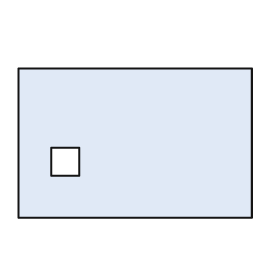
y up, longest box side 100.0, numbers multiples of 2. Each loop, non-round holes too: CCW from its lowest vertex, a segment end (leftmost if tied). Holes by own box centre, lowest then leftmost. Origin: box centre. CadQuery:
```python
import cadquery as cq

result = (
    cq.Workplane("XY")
    .moveTo(-50.0, -32.0)
    .lineTo(50.0, -32.0)
    .lineTo(50.0, 32.0)
    .lineTo(-50.0, 32.0)
    .close()
    .moveTo(-36.0, -14.0)
    .lineTo(-24.0, -14.0)
    .lineTo(-24.0, -2.0)
    .lineTo(-36.0, -2.0)
    .close()
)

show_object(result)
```